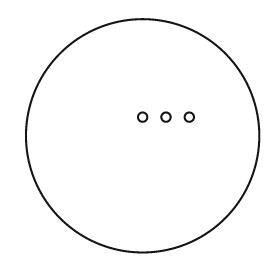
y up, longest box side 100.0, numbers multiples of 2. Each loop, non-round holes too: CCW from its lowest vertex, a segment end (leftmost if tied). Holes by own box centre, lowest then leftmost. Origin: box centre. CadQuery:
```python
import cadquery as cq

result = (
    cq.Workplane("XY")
    .moveTo(0.0, 0.0)
    .circle(50.0)
    .moveTo(0.0, 8.0)
    .circle(2.0)
    .moveTo(10.0, 8.0)
    .circle(2.0)
    .moveTo(20.0, 8.0)
    .circle(2.0)
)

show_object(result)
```